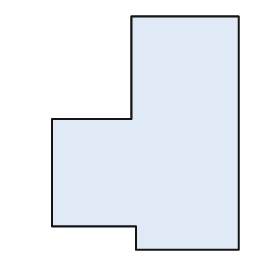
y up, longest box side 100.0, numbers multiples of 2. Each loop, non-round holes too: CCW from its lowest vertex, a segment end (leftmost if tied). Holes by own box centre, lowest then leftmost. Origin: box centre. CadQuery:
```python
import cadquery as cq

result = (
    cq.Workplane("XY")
    .moveTo(-4.0, -50.0)
    .lineTo(40.0, -50.0)
    .lineTo(40.0, 50.0)
    .lineTo(-6.0, 50.0)
    .lineTo(-6.0, 6.0)
    .lineTo(-40.0, 6.0)
    .lineTo(-40.0, -40.0)
    .lineTo(-4.0, -40.0)
    .close()
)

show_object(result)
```